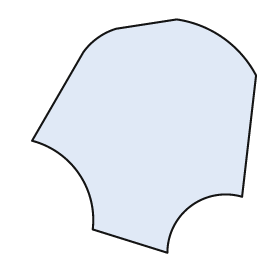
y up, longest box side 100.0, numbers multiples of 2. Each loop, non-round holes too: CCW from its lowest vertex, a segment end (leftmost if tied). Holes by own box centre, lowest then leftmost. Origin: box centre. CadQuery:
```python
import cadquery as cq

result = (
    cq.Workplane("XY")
    .moveTo(10.0, -50.0)
    .threePointArc((20.0, -30.0), (42.0, -26.0))
    .lineTo(48.0, 26.0)
    .threePointArc((34.0, 42.0), (14.0, 50.0))
    .lineTo(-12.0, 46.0)
    .threePointArc((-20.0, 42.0), (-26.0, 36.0))
    .lineTo(-48.0, -2.0)
    .threePointArc((-28.0, -16.0), (-22.0, -40.0))
    .close()
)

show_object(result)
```